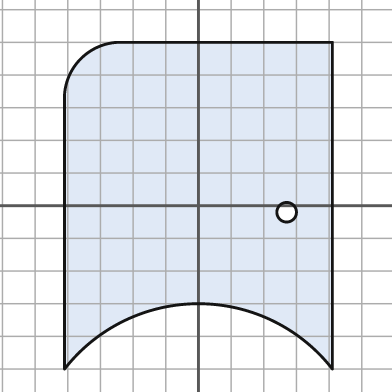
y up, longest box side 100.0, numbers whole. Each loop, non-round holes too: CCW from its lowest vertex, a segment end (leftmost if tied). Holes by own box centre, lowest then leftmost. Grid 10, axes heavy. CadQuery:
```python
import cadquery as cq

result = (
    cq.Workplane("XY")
    .moveTo(-41.0, -50.0)
    .threePointArc((0.0, -30.0), (41.0, -50.0))
    .lineTo(41.0, 50.0)
    .lineTo(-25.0, 50.0)
    .threePointArc((-36.0, 45.0), (-41.0, 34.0))
    .close()
    .moveTo(27.0, -2.0)
    .circle(3.0)
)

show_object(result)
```